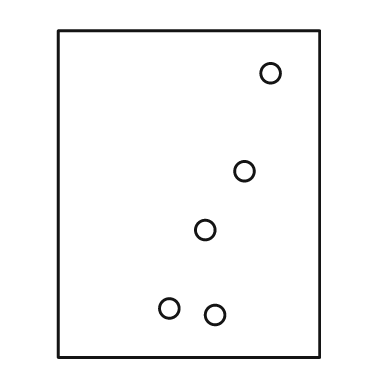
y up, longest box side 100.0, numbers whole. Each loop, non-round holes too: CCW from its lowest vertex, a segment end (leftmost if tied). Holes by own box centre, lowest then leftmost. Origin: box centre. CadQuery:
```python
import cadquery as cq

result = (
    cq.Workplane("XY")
    .moveTo(-40.0, -50.0)
    .lineTo(40.0, -50.0)
    .lineTo(40.0, 50.0)
    .lineTo(-40.0, 50.0)
    .close()
    .moveTo(8.0, -37.0)
    .circle(3.0)
    .moveTo(-6.0, -35.0)
    .circle(3.0)
    .moveTo(5.0, -11.0)
    .circle(3.0)
    .moveTo(17.0, 7.0)
    .circle(3.0)
    .moveTo(25.0, 37.0)
    .circle(3.0)
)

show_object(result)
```